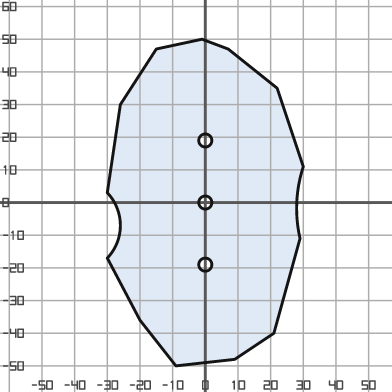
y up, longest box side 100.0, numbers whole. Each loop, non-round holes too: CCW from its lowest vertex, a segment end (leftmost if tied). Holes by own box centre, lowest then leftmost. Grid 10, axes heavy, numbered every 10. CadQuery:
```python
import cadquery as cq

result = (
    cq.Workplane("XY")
    .moveTo(-9.0, -50.0)
    .lineTo(9.0, -48.0)
    .lineTo(21.0, -40.0)
    .lineTo(29.0, -11.0)
    .threePointArc((28.0, 0.0), (30.0, 11.0))
    .lineTo(22.0, 35.0)
    .lineTo(7.0, 47.0)
    .lineTo(-1.0, 50.0)
    .lineTo(-15.0, 47.0)
    .lineTo(-26.0, 30.0)
    .lineTo(-30.0, 3.0)
    .threePointArc((-26.0, -7.0), (-30.0, -17.0))
    .lineTo(-20.0, -36.0)
    .close()
    .moveTo(0.0, -19.0)
    .circle(2.0)
    .moveTo(0.0, 0.0)
    .circle(2.0)
    .moveTo(0.0, 19.0)
    .circle(2.0)
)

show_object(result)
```